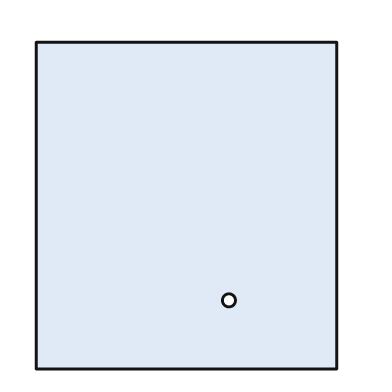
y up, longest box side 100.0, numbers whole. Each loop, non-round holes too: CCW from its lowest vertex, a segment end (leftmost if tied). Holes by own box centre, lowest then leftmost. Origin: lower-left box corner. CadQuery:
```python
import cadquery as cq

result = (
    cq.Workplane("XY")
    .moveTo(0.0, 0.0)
    .lineTo(92.0, 0.0)
    .lineTo(92.0, 100.0)
    .lineTo(0.0, 100.0)
    .close()
    .moveTo(59.0, 21.0)
    .circle(2.0)
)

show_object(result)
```